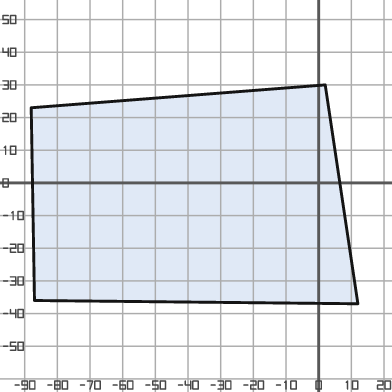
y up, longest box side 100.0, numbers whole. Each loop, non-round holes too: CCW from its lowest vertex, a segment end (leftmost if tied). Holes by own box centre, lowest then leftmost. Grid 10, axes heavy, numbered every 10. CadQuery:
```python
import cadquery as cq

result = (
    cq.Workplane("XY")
    .moveTo(12.0, -37.0)
    .lineTo(2.0, 30.0)
    .lineTo(-88.0, 23.0)
    .lineTo(-87.0, -36.0)
    .close()
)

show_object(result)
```